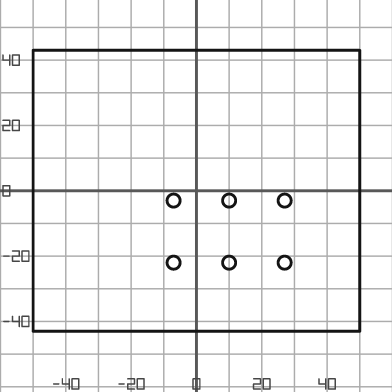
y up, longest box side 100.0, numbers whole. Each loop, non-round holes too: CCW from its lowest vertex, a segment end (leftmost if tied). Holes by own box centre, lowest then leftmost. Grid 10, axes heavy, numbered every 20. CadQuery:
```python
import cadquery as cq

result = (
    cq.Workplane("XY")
    .moveTo(-50.0, -43.0)
    .lineTo(50.0, -43.0)
    .lineTo(50.0, 43.0)
    .lineTo(-50.0, 43.0)
    .close()
    .moveTo(-7.0, -22.0)
    .circle(2.0)
    .moveTo(10.0, -22.0)
    .circle(2.0)
    .moveTo(27.0, -22.0)
    .circle(2.0)
    .moveTo(-7.0, -3.0)
    .circle(2.0)
    .moveTo(10.0, -3.0)
    .circle(2.0)
    .moveTo(27.0, -3.0)
    .circle(2.0)
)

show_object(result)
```